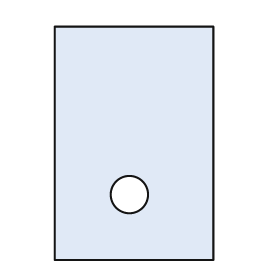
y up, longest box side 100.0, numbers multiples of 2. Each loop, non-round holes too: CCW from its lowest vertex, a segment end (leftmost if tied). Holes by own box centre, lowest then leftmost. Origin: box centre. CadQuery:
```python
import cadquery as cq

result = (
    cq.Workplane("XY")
    .moveTo(-34.0, -50.0)
    .lineTo(34.0, -50.0)
    .lineTo(34.0, 50.0)
    .lineTo(-34.0, 50.0)
    .close()
    .moveTo(-2.0, -22.0)
    .circle(8.0)
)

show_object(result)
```